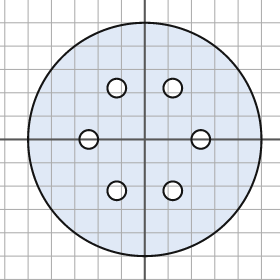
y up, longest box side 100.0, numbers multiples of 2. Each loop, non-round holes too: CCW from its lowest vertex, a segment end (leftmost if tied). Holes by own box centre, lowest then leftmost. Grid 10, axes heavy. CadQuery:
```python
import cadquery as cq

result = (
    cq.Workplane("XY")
    .moveTo(0.0, 0.0)
    .circle(50.0)
    .moveTo(-12.0, -22.0)
    .circle(4.0)
    .moveTo(12.0, -22.0)
    .circle(4.0)
    .moveTo(-24.0, 0.0)
    .circle(4.0)
    .moveTo(24.0, 0.0)
    .circle(4.0)
    .moveTo(-12.0, 22.0)
    .circle(4.0)
    .moveTo(12.0, 22.0)
    .circle(4.0)
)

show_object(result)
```